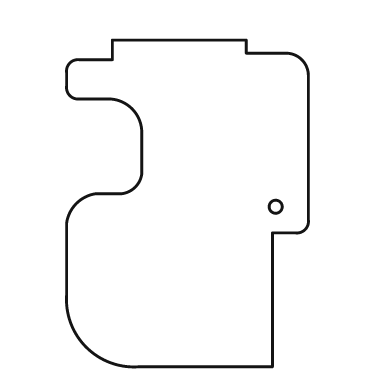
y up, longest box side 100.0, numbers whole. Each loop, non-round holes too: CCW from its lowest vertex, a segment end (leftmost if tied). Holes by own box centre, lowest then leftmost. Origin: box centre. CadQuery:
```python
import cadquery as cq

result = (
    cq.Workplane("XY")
    .moveTo(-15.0, -50.0)
    .lineTo(26.0, -50.0)
    .lineTo(26.0, -9.0)
    .lineTo(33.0, -9.0)
    .threePointArc((36.0, -8.0), (37.0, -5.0))
    .lineTo(37.0, 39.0)
    .threePointArc((35.0, 44.0), (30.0, 46.0))
    .lineTo(18.0, 46.0)
    .lineTo(18.0, 50.0)
    .lineTo(-23.0, 50.0)
    .lineTo(-23.0, 44.0)
    .lineTo(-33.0, 44.0)
    .threePointArc((-36.0, 43.0), (-37.0, 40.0))
    .lineTo(-37.0, 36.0)
    .threePointArc((-36.0, 33.0), (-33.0, 32.0))
    .lineTo(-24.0, 32.0)
    .threePointArc((-17.0, 29.0), (-14.0, 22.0))
    .lineTo(-14.0, 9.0)
    .threePointArc((-16.0, 5.0), (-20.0, 3.0))
    .lineTo(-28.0, 3.0)
    .threePointArc((-34.0, 0.0), (-37.0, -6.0))
    .lineTo(-37.0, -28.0)
    .threePointArc((-31.0, -44.0), (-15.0, -50.0))
    .close()
    .moveTo(27.0, -1.0)
    .circle(2.0)
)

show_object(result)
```